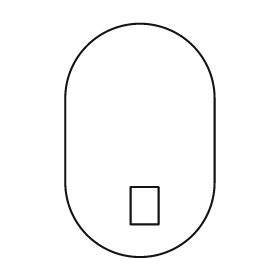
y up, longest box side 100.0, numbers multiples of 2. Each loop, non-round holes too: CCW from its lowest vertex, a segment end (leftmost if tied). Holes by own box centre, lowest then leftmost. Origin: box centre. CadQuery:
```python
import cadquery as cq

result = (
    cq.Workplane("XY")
    .moveTo(-32.0, -18.0)
    .threePointArc((0.0, -50.0), (32.0, -18.0))
    .lineTo(32.0, 18.0)
    .threePointArc((0.0, 50.0), (-32.0, 18.0))
    .close()
    .moveTo(-4.0, -36.0)
    .lineTo(8.0, -36.0)
    .lineTo(8.0, -20.0)
    .lineTo(-4.0, -20.0)
    .close()
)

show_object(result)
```